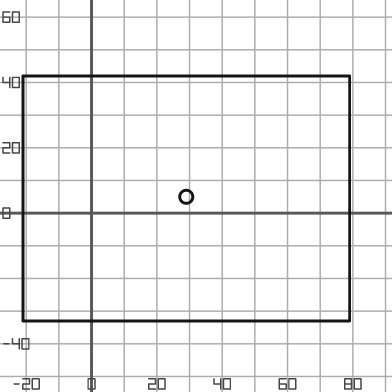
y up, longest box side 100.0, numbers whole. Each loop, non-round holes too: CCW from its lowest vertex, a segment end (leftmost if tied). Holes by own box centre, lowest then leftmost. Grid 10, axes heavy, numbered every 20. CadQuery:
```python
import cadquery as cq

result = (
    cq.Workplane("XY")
    .moveTo(-21.0, -33.0)
    .lineTo(79.0, -33.0)
    .lineTo(79.0, 42.0)
    .lineTo(-21.0, 42.0)
    .close()
    .moveTo(29.0, 5.0)
    .circle(2.0)
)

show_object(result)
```